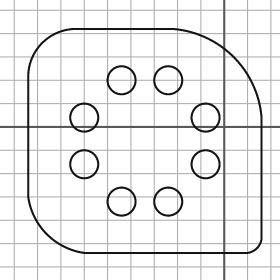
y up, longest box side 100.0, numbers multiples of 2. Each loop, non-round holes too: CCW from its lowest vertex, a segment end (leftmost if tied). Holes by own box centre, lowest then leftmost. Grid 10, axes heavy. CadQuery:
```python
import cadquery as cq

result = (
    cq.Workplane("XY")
    .moveTo(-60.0, -54.0)
    .lineTo(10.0, -54.0)
    .threePointArc((14.0, -52.0), (16.0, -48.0))
    .lineTo(16.0, 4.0)
    .threePointArc((4.0, 30.0), (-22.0, 42.0))
    .lineTo(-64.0, 42.0)
    .threePointArc((-78.0, 36.0), (-84.0, 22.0))
    .lineTo(-84.0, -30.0)
    .threePointArc((-76.0, -46.0), (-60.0, -54.0))
    .close()
    .moveTo(-44.0, -32.0)
    .circle(6.0)
    .moveTo(-24.0, -32.0)
    .circle(6.0)
    .moveTo(-60.0, -16.0)
    .circle(6.0)
    .moveTo(-8.0, -16.0)
    .circle(6.0)
    .moveTo(-60.0, 4.0)
    .circle(6.0)
    .moveTo(-8.0, 4.0)
    .circle(6.0)
    .moveTo(-44.0, 20.0)
    .circle(6.0)
    .moveTo(-24.0, 20.0)
    .circle(6.0)
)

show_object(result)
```